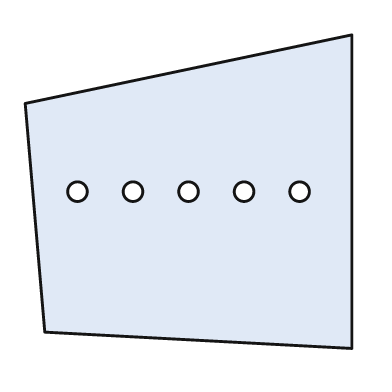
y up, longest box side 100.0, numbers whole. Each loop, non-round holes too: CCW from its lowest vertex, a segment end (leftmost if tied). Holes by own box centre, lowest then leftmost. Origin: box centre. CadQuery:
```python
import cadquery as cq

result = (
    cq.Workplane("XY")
    .moveTo(50.0, -48.0)
    .lineTo(50.0, 48.0)
    .lineTo(-50.0, 27.0)
    .lineTo(-44.0, -43.0)
    .close()
    .moveTo(-34.0, 0.0)
    .circle(3.0)
    .moveTo(-17.0, 0.0)
    .circle(3.0)
    .moveTo(0.0, 0.0)
    .circle(3.0)
    .moveTo(17.0, 0.0)
    .circle(3.0)
    .moveTo(34.0, 0.0)
    .circle(3.0)
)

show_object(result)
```